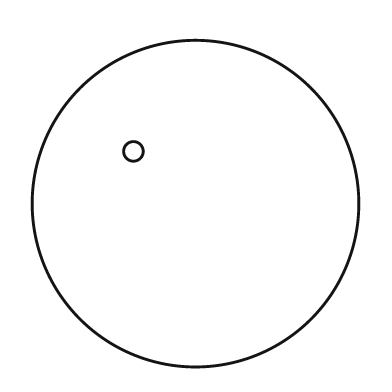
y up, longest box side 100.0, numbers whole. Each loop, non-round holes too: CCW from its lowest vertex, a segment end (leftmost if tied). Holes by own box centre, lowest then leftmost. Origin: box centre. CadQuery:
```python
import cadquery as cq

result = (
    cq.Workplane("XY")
    .moveTo(0.0, 0.0)
    .circle(50.0)
    .moveTo(-19.0, 16.0)
    .circle(3.0)
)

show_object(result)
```